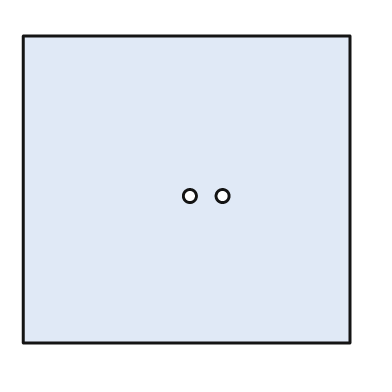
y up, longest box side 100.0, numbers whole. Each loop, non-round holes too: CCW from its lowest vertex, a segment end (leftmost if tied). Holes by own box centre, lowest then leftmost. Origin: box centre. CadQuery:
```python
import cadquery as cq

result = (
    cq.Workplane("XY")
    .moveTo(-50.0, -47.0)
    .lineTo(50.0, -47.0)
    .lineTo(50.0, 47.0)
    .lineTo(-50.0, 47.0)
    .close()
    .moveTo(1.0, -2.0)
    .circle(2.0)
    .moveTo(11.0, -2.0)
    .circle(2.0)
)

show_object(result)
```